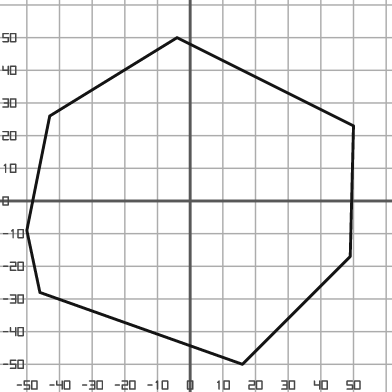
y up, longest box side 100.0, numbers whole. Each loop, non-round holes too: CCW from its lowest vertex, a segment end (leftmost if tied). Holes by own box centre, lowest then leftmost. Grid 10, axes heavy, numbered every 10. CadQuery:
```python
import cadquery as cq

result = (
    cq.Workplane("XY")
    .moveTo(16.0, -50.0)
    .lineTo(49.0, -17.0)
    .lineTo(50.0, 23.0)
    .lineTo(-4.0, 50.0)
    .lineTo(-43.0, 26.0)
    .lineTo(-50.0, -9.0)
    .lineTo(-46.0, -28.0)
    .close()
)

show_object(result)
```